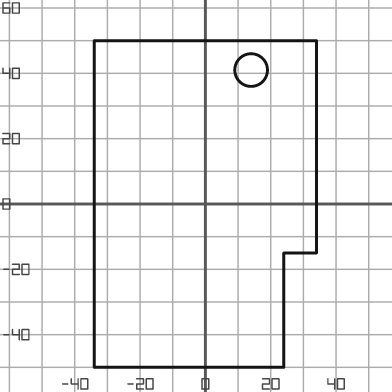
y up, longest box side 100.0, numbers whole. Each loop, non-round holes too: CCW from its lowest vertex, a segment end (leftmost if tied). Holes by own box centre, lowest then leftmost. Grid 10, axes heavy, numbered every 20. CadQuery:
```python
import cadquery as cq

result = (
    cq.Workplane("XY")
    .moveTo(-34.0, -50.0)
    .lineTo(24.0, -50.0)
    .lineTo(24.0, -15.0)
    .lineTo(34.0, -15.0)
    .lineTo(34.0, 50.0)
    .lineTo(-34.0, 50.0)
    .close()
    .moveTo(14.0, 41.0)
    .circle(5.0)
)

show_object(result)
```